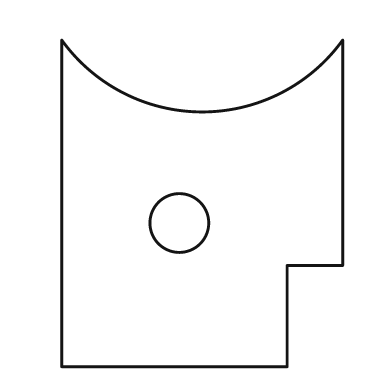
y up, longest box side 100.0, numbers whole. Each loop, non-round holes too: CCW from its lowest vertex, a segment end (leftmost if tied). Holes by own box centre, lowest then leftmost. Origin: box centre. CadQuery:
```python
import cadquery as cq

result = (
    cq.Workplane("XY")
    .moveTo(-43.0, -50.0)
    .lineTo(26.0, -50.0)
    .lineTo(26.0, -19.0)
    .lineTo(43.0, -19.0)
    .lineTo(43.0, 50.0)
    .threePointArc((0.0, 28.0), (-43.0, 50.0))
    .close()
    .moveTo(-7.0, -6.0)
    .circle(9.0)
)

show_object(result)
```